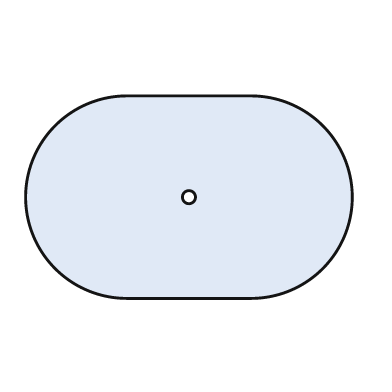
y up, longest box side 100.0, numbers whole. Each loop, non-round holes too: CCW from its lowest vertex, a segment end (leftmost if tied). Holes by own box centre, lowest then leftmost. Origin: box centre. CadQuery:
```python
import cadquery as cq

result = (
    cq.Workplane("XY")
    .moveTo(-19.0, -31.0)
    .lineTo(19.0, -31.0)
    .threePointArc((50.0, 0.0), (19.0, 31.0))
    .lineTo(-19.0, 31.0)
    .threePointArc((-50.0, 0.0), (-19.0, -31.0))
    .close()
    .moveTo(0.0, 0.0)
    .circle(2.0)
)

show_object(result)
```